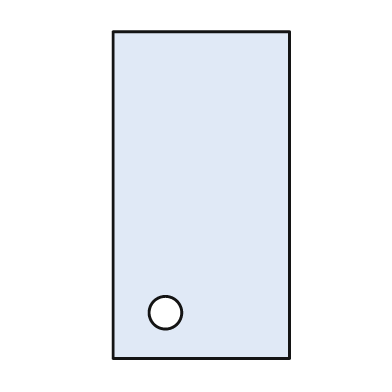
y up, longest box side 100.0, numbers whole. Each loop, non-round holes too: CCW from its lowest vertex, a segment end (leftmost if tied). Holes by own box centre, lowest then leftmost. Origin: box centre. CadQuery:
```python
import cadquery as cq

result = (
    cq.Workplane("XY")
    .moveTo(-27.0, -50.0)
    .lineTo(27.0, -50.0)
    .lineTo(27.0, 50.0)
    .lineTo(-27.0, 50.0)
    .close()
    .moveTo(-11.0, -36.0)
    .circle(5.0)
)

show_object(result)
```